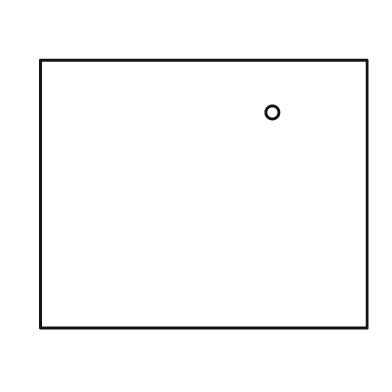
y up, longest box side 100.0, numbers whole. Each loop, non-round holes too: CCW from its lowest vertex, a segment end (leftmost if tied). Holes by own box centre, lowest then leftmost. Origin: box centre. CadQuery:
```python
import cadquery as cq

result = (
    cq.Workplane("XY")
    .moveTo(-50.0, -41.0)
    .lineTo(50.0, -41.0)
    .lineTo(50.0, 41.0)
    .lineTo(-50.0, 41.0)
    .close()
    .moveTo(21.0, 25.0)
    .circle(2.0)
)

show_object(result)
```